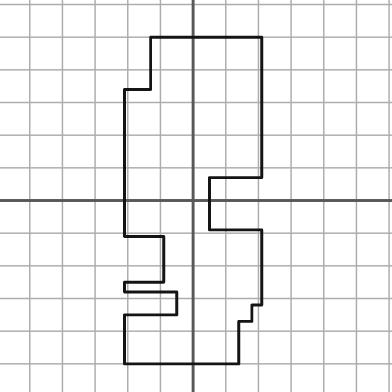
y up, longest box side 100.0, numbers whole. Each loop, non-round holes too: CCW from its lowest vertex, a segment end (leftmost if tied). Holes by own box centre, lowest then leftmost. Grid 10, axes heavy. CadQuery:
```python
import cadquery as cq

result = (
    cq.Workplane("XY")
    .moveTo(-21.0, -50.0)
    .lineTo(14.0, -50.0)
    .lineTo(14.0, -37.0)
    .lineTo(18.0, -37.0)
    .lineTo(18.0, -32.0)
    .lineTo(21.0, -32.0)
    .lineTo(21.0, -9.0)
    .lineTo(5.0, -9.0)
    .lineTo(5.0, 7.0)
    .lineTo(21.0, 7.0)
    .lineTo(21.0, 50.0)
    .lineTo(-13.0, 50.0)
    .lineTo(-13.0, 34.0)
    .lineTo(-21.0, 34.0)
    .lineTo(-21.0, -11.0)
    .lineTo(-9.0, -11.0)
    .lineTo(-9.0, -25.0)
    .lineTo(-21.0, -25.0)
    .lineTo(-21.0, -28.0)
    .lineTo(-5.0, -28.0)
    .lineTo(-5.0, -35.0)
    .lineTo(-21.0, -35.0)
    .close()
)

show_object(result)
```